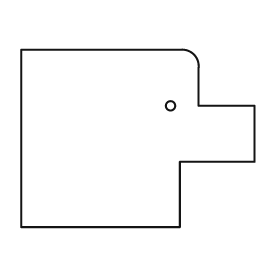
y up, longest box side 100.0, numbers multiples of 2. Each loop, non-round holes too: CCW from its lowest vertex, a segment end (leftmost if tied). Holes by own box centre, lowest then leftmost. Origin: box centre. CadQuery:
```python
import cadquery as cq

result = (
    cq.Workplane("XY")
    .moveTo(-50.0, -38.0)
    .lineTo(18.0, -38.0)
    .lineTo(18.0, -10.0)
    .lineTo(50.0, -10.0)
    .lineTo(50.0, 14.0)
    .lineTo(26.0, 14.0)
    .lineTo(26.0, 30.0)
    .threePointArc((24.0, 36.0), (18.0, 38.0))
    .lineTo(-50.0, 38.0)
    .close()
    .moveTo(14.0, 14.0)
    .circle(2.0)
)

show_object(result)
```